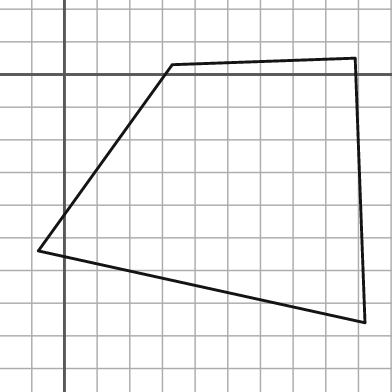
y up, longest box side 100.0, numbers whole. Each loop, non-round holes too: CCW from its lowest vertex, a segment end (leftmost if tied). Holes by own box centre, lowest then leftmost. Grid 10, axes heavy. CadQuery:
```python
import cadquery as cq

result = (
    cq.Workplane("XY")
    .moveTo(92.0, -76.0)
    .lineTo(89.0, 5.0)
    .lineTo(33.0, 3.0)
    .lineTo(-8.0, -54.0)
    .close()
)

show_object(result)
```